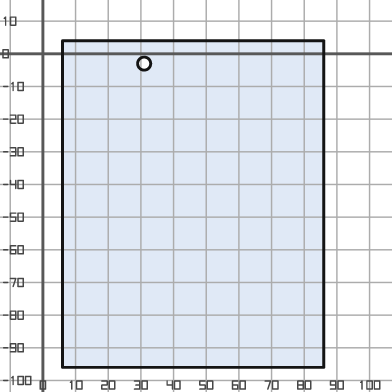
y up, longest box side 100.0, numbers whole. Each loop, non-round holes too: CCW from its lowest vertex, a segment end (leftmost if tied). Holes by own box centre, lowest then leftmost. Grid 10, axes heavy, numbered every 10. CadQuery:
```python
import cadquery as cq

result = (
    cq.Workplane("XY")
    .moveTo(6.0, -96.0)
    .lineTo(86.0, -96.0)
    .lineTo(86.0, 4.0)
    .lineTo(6.0, 4.0)
    .close()
    .moveTo(31.0, -3.0)
    .circle(2.0)
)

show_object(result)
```